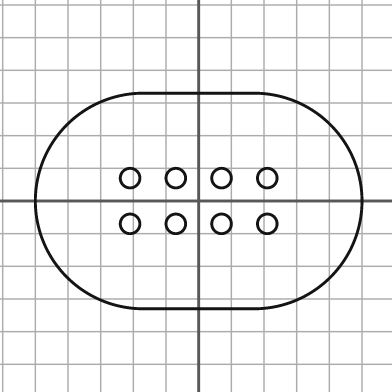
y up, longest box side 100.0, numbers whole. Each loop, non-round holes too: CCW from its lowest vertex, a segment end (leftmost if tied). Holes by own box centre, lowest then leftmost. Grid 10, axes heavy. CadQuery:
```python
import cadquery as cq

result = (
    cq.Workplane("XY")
    .moveTo(-17.0, -33.0)
    .lineTo(17.0, -33.0)
    .threePointArc((50.0, 0.0), (17.0, 33.0))
    .lineTo(-17.0, 33.0)
    .threePointArc((-50.0, 0.0), (-17.0, -33.0))
    .close()
    .moveTo(-21.0, -7.0)
    .circle(3.0)
    .moveTo(-7.0, -7.0)
    .circle(3.0)
    .moveTo(7.0, -7.0)
    .circle(3.0)
    .moveTo(21.0, -7.0)
    .circle(3.0)
    .moveTo(-21.0, 7.0)
    .circle(3.0)
    .moveTo(-7.0, 7.0)
    .circle(3.0)
    .moveTo(7.0, 7.0)
    .circle(3.0)
    .moveTo(21.0, 7.0)
    .circle(3.0)
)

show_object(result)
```